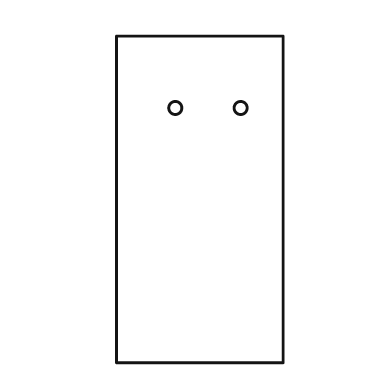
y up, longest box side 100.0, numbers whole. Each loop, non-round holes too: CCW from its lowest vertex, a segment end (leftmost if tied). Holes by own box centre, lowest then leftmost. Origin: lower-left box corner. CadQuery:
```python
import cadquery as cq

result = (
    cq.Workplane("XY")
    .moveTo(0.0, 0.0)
    .lineTo(51.0, 0.0)
    .lineTo(51.0, 100.0)
    .lineTo(0.0, 100.0)
    .close()
    .moveTo(18.0, 78.0)
    .circle(2.0)
    .moveTo(38.0, 78.0)
    .circle(2.0)
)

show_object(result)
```